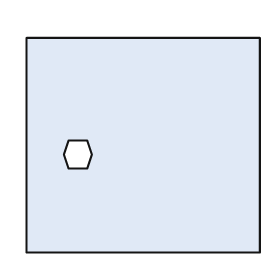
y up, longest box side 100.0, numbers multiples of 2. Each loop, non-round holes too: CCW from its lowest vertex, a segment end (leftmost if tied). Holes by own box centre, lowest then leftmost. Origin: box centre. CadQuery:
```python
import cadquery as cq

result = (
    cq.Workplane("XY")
    .moveTo(-50.0, -46.0)
    .lineTo(50.0, -46.0)
    .lineTo(50.0, 46.0)
    .lineTo(-50.0, 46.0)
    .close()
    .moveTo(-32.0, -10.0)
    .lineTo(-24.0, -10.0)
    .lineTo(-22.0, -4.0)
    .lineTo(-24.0, 2.0)
    .lineTo(-32.0, 2.0)
    .lineTo(-34.0, -4.0)
    .close()
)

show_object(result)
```